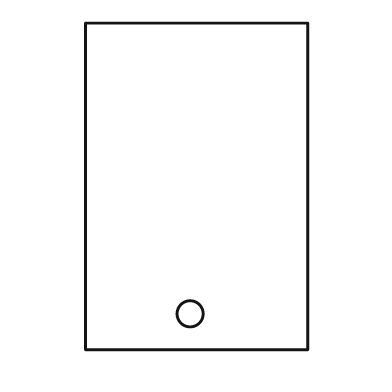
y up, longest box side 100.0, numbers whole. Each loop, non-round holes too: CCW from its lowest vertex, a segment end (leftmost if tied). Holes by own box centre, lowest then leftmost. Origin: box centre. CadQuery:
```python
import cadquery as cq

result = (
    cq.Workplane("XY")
    .moveTo(-34.0, -50.0)
    .lineTo(34.0, -50.0)
    .lineTo(34.0, 50.0)
    .lineTo(-34.0, 50.0)
    .close()
    .moveTo(-2.0, -39.0)
    .circle(4.0)
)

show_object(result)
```